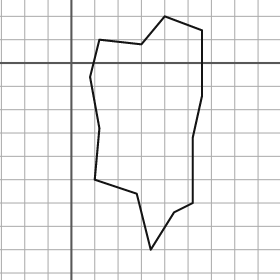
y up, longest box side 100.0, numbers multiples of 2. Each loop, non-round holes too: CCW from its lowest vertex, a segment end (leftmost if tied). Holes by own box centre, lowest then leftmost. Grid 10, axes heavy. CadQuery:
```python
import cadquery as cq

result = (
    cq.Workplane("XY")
    .moveTo(34.0, -80.0)
    .lineTo(44.0, -64.0)
    .lineTo(52.0, -60.0)
    .lineTo(52.0, -32.0)
    .lineTo(56.0, -14.0)
    .lineTo(56.0, 14.0)
    .lineTo(40.0, 20.0)
    .lineTo(30.0, 8.0)
    .lineTo(12.0, 10.0)
    .lineTo(8.0, -6.0)
    .lineTo(12.0, -28.0)
    .lineTo(10.0, -50.0)
    .lineTo(28.0, -56.0)
    .close()
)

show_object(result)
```